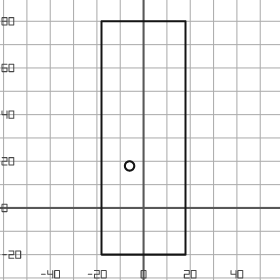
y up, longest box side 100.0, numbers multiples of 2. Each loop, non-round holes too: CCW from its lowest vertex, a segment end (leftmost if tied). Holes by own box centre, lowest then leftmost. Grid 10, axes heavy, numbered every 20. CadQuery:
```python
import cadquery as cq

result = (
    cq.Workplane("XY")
    .moveTo(-18.0, -20.0)
    .lineTo(18.0, -20.0)
    .lineTo(18.0, 80.0)
    .lineTo(-18.0, 80.0)
    .close()
    .moveTo(-6.0, 18.0)
    .circle(2.0)
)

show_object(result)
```